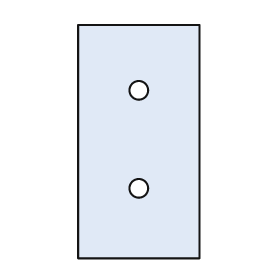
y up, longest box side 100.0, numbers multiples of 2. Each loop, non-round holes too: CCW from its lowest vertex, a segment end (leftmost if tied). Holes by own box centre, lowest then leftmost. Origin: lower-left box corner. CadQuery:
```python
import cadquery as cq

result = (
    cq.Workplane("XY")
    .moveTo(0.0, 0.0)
    .lineTo(52.0, 0.0)
    .lineTo(52.0, 100.0)
    .lineTo(0.0, 100.0)
    .close()
    .moveTo(26.0, 30.0)
    .circle(4.0)
    .moveTo(26.0, 72.0)
    .circle(4.0)
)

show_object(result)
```